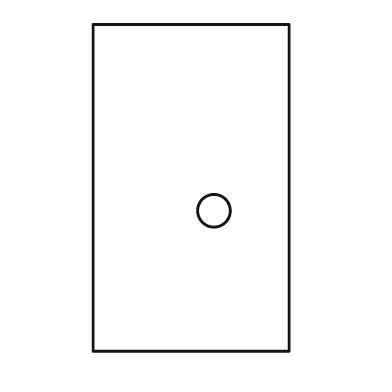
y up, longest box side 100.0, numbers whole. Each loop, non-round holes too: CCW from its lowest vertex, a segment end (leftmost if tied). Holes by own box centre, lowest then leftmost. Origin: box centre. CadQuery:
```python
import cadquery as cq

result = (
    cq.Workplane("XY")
    .moveTo(-30.0, -50.0)
    .lineTo(30.0, -50.0)
    .lineTo(30.0, 50.0)
    .lineTo(-30.0, 50.0)
    .close()
    .moveTo(7.0, -7.0)
    .circle(5.0)
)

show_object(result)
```